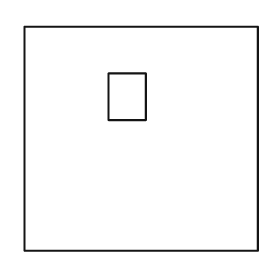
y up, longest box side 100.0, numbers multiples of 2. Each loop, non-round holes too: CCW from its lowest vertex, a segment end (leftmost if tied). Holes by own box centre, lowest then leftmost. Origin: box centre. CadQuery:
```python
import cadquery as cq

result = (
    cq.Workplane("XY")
    .moveTo(-50.0, -48.0)
    .lineTo(50.0, -48.0)
    .lineTo(50.0, 48.0)
    .lineTo(-50.0, 48.0)
    .close()
    .moveTo(-14.0, 8.0)
    .lineTo(2.0, 8.0)
    .lineTo(2.0, 28.0)
    .lineTo(-14.0, 28.0)
    .close()
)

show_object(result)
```